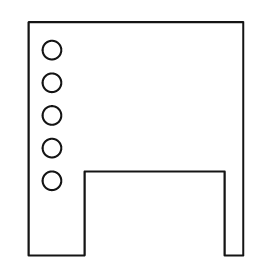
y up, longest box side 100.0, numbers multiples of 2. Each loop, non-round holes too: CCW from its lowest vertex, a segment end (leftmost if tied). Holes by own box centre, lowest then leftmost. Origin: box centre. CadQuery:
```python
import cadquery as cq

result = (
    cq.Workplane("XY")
    .moveTo(-46.0, -50.0)
    .lineTo(-22.0, -50.0)
    .lineTo(-22.0, -14.0)
    .lineTo(38.0, -14.0)
    .lineTo(38.0, -50.0)
    .lineTo(46.0, -50.0)
    .lineTo(46.0, 50.0)
    .lineTo(-46.0, 50.0)
    .close()
    .moveTo(-36.0, -18.0)
    .circle(4.0)
    .moveTo(-36.0, -4.0)
    .circle(4.0)
    .moveTo(-36.0, 10.0)
    .circle(4.0)
    .moveTo(-36.0, 24.0)
    .circle(4.0)
    .moveTo(-36.0, 38.0)
    .circle(4.0)
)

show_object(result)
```